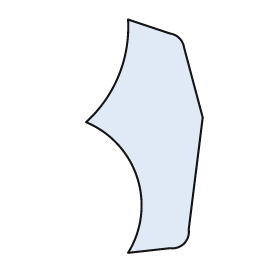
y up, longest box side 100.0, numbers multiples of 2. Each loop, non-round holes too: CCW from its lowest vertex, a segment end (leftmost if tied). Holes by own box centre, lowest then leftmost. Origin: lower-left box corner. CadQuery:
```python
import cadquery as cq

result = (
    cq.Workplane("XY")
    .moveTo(18.0, 0.0)
    .lineTo(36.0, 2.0)
    .threePointArc((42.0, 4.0), (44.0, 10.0))
    .lineTo(50.0, 58.0)
    .lineTo(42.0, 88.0)
    .threePointArc((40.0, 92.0), (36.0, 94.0))
    .lineTo(18.0, 100.0)
    .threePointArc((14.0, 76.0), (0.0, 56.0))
    .threePointArc((22.0, 32.0), (18.0, 0.0))
    .close()
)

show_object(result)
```